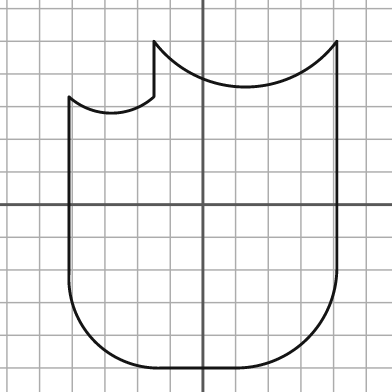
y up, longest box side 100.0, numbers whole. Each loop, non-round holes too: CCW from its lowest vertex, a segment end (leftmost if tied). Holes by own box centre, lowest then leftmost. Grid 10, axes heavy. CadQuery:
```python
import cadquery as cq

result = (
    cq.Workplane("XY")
    .moveTo(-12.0, -50.0)
    .lineTo(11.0, -50.0)
    .threePointArc((32.0, -41.0), (41.0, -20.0))
    .lineTo(41.0, 50.0)
    .threePointArc((13.0, 36.0), (-15.0, 50.0))
    .lineTo(-15.0, 33.0)
    .threePointArc((-28.0, 28.0), (-41.0, 33.0))
    .lineTo(-41.0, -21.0)
    .threePointArc((-33.0, -42.0), (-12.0, -50.0))
    .close()
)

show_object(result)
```